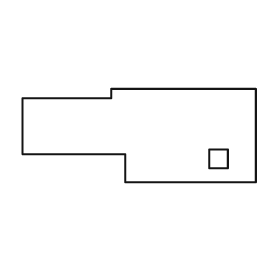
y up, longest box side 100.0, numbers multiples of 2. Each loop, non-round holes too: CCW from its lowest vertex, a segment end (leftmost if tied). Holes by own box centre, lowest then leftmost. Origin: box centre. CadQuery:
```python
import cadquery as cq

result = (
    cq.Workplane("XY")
    .moveTo(-6.0, -20.0)
    .lineTo(50.0, -20.0)
    .lineTo(50.0, 20.0)
    .lineTo(-12.0, 20.0)
    .lineTo(-12.0, 16.0)
    .lineTo(-50.0, 16.0)
    .lineTo(-50.0, -8.0)
    .lineTo(-6.0, -8.0)
    .close()
    .moveTo(30.0, -14.0)
    .lineTo(38.0, -14.0)
    .lineTo(38.0, -6.0)
    .lineTo(30.0, -6.0)
    .close()
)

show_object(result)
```